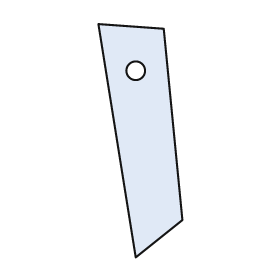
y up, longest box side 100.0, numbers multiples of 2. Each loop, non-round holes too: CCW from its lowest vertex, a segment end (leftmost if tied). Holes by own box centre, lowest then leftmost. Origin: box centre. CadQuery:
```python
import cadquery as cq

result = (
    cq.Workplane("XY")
    .moveTo(-2.0, -50.0)
    .lineTo(18.0, -34.0)
    .lineTo(10.0, 48.0)
    .lineTo(-18.0, 50.0)
    .close()
    .moveTo(-2.0, 30.0)
    .circle(4.0)
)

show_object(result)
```